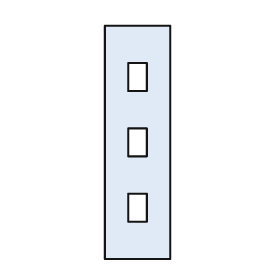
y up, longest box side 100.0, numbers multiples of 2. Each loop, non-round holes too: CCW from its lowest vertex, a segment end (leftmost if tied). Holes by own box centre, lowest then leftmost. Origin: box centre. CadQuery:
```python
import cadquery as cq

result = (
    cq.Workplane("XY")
    .moveTo(-14.0, -50.0)
    .lineTo(14.0, -50.0)
    .lineTo(14.0, 50.0)
    .lineTo(-14.0, 50.0)
    .close()
    .moveTo(-4.0, -34.0)
    .lineTo(4.0, -34.0)
    .lineTo(4.0, -22.0)
    .lineTo(-4.0, -22.0)
    .close()
    .moveTo(-4.0, -6.0)
    .lineTo(4.0, -6.0)
    .lineTo(4.0, 6.0)
    .lineTo(-4.0, 6.0)
    .close()
    .moveTo(-4.0, 22.0)
    .lineTo(4.0, 22.0)
    .lineTo(4.0, 34.0)
    .lineTo(-4.0, 34.0)
    .close()
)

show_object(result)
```